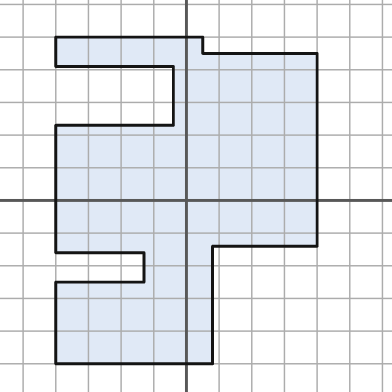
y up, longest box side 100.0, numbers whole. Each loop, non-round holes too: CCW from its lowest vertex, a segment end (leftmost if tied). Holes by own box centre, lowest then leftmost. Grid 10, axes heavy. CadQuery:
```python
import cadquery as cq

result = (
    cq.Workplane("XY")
    .moveTo(-40.0, -50.0)
    .lineTo(8.0, -50.0)
    .lineTo(8.0, -14.0)
    .lineTo(40.0, -14.0)
    .lineTo(40.0, 45.0)
    .lineTo(5.0, 45.0)
    .lineTo(5.0, 50.0)
    .lineTo(-40.0, 50.0)
    .lineTo(-40.0, 41.0)
    .lineTo(-4.0, 41.0)
    .lineTo(-4.0, 23.0)
    .lineTo(-40.0, 23.0)
    .lineTo(-40.0, -16.0)
    .lineTo(-13.0, -16.0)
    .lineTo(-13.0, -25.0)
    .lineTo(-40.0, -25.0)
    .close()
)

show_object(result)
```